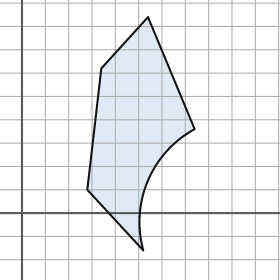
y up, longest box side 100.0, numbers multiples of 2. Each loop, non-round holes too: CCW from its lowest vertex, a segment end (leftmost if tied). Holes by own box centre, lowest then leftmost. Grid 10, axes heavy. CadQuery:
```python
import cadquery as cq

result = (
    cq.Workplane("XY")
    .moveTo(52.0, -16.0)
    .threePointArc((54.0, 14.0), (74.0, 36.0))
    .lineTo(54.0, 84.0)
    .lineTo(34.0, 62.0)
    .lineTo(28.0, 10.0)
    .close()
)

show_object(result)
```